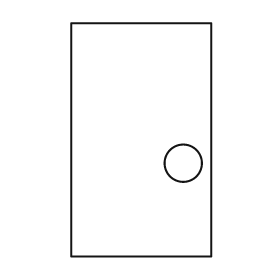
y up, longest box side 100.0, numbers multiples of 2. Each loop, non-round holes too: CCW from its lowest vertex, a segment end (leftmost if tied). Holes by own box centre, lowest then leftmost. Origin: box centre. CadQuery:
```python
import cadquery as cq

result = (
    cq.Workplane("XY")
    .moveTo(-30.0, -50.0)
    .lineTo(30.0, -50.0)
    .lineTo(30.0, 50.0)
    .lineTo(-30.0, 50.0)
    .close()
    .moveTo(18.0, -10.0)
    .circle(8.0)
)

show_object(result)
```